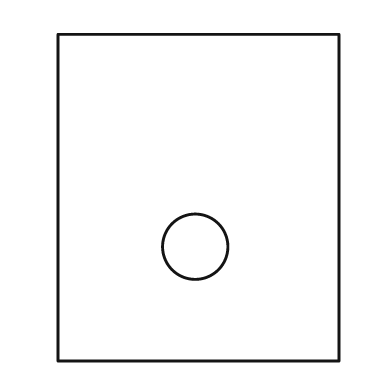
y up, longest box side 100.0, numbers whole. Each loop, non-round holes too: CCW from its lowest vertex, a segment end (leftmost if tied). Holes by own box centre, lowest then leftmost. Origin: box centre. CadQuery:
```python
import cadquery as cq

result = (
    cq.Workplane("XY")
    .moveTo(-43.0, -50.0)
    .lineTo(43.0, -50.0)
    .lineTo(43.0, 50.0)
    .lineTo(-43.0, 50.0)
    .close()
    .moveTo(-1.0, -15.0)
    .circle(10.0)
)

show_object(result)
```